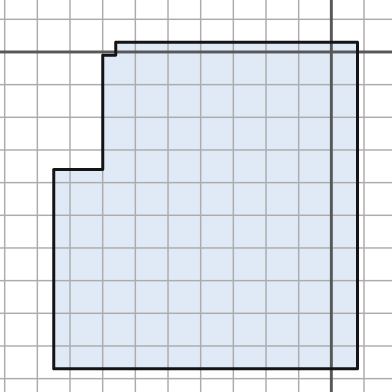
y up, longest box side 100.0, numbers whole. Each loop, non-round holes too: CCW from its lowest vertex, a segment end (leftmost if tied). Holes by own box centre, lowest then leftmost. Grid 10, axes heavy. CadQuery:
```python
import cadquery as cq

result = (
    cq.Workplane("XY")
    .moveTo(-85.0, -97.0)
    .lineTo(8.0, -97.0)
    .lineTo(8.0, 3.0)
    .lineTo(-66.0, 3.0)
    .lineTo(-66.0, -1.0)
    .lineTo(-70.0, -1.0)
    .lineTo(-70.0, -36.0)
    .lineTo(-85.0, -36.0)
    .close()
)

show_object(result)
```